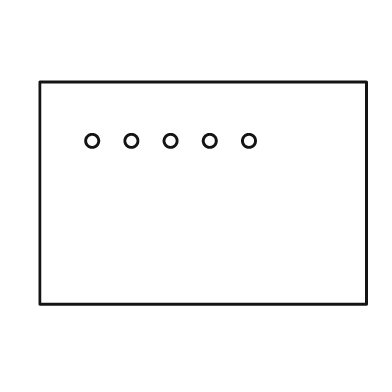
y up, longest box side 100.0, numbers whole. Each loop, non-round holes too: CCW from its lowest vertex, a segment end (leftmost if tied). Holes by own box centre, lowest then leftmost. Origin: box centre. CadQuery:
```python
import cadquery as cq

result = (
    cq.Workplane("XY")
    .moveTo(-50.0, -34.0)
    .lineTo(50.0, -34.0)
    .lineTo(50.0, 34.0)
    .lineTo(-50.0, 34.0)
    .close()
    .moveTo(-34.0, 16.0)
    .circle(2.0)
    .moveTo(-22.0, 16.0)
    .circle(2.0)
    .moveTo(-10.0, 16.0)
    .circle(2.0)
    .moveTo(2.0, 16.0)
    .circle(2.0)
    .moveTo(14.0, 16.0)
    .circle(2.0)
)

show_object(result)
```